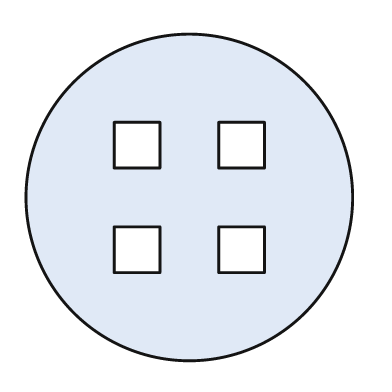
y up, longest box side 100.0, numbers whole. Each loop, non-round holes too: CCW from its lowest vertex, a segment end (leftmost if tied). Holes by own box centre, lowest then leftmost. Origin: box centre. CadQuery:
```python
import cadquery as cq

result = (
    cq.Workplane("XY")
    .moveTo(0.0, 0.0)
    .circle(50.0)
    .moveTo(-23.0, -23.0)
    .lineTo(-9.0, -23.0)
    .lineTo(-9.0, -9.0)
    .lineTo(-23.0, -9.0)
    .close()
    .moveTo(9.0, -23.0)
    .lineTo(23.0, -23.0)
    .lineTo(23.0, -9.0)
    .lineTo(9.0, -9.0)
    .close()
    .moveTo(-23.0, 9.0)
    .lineTo(-9.0, 9.0)
    .lineTo(-9.0, 23.0)
    .lineTo(-23.0, 23.0)
    .close()
    .moveTo(9.0, 9.0)
    .lineTo(23.0, 9.0)
    .lineTo(23.0, 23.0)
    .lineTo(9.0, 23.0)
    .close()
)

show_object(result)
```